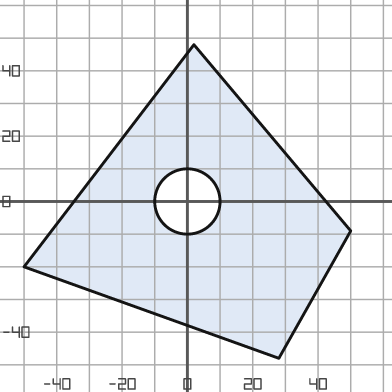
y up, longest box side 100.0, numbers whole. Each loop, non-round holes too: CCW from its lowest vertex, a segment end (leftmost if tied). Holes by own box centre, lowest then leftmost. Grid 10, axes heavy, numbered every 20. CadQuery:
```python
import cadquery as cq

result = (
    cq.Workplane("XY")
    .moveTo(28.0, -48.0)
    .lineTo(50.0, -9.0)
    .lineTo(2.0, 48.0)
    .lineTo(-50.0, -20.0)
    .close()
    .moveTo(0.0, 0.0)
    .circle(10.0)
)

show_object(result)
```